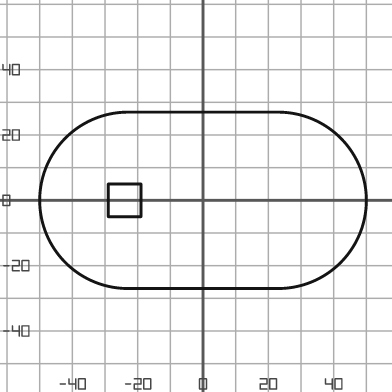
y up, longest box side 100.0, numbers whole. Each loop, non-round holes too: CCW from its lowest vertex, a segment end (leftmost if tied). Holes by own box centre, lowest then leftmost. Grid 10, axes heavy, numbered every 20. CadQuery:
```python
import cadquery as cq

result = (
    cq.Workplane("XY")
    .moveTo(-23.0, -27.0)
    .lineTo(23.0, -27.0)
    .threePointArc((50.0, 0.0), (23.0, 27.0))
    .lineTo(-23.0, 27.0)
    .threePointArc((-50.0, 0.0), (-23.0, -27.0))
    .close()
    .moveTo(-29.0, -5.0)
    .lineTo(-19.0, -5.0)
    .lineTo(-19.0, 5.0)
    .lineTo(-29.0, 5.0)
    .close()
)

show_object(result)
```